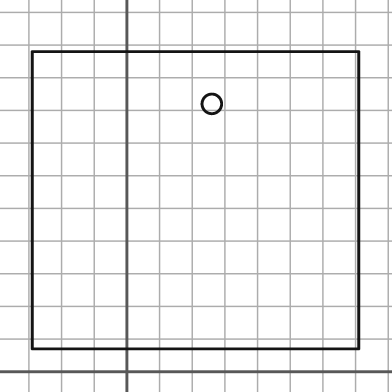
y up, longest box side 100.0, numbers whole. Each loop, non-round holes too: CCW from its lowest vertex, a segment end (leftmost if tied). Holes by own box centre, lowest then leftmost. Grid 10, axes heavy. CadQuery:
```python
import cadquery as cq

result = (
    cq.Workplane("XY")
    .moveTo(-29.0, 7.0)
    .lineTo(71.0, 7.0)
    .lineTo(71.0, 98.0)
    .lineTo(-29.0, 98.0)
    .close()
    .moveTo(26.0, 82.0)
    .circle(3.0)
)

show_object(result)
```